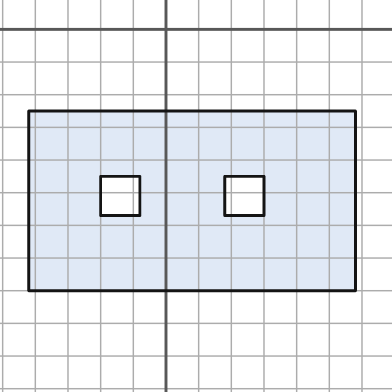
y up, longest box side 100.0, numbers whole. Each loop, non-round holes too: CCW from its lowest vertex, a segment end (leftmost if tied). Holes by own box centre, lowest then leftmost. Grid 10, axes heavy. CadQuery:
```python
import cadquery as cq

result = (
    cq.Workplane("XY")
    .moveTo(-42.0, -80.0)
    .lineTo(58.0, -80.0)
    .lineTo(58.0, -25.0)
    .lineTo(-42.0, -25.0)
    .close()
    .moveTo(-20.0, -57.0)
    .lineTo(-8.0, -57.0)
    .lineTo(-8.0, -45.0)
    .lineTo(-20.0, -45.0)
    .close()
    .moveTo(18.0, -57.0)
    .lineTo(30.0, -57.0)
    .lineTo(30.0, -45.0)
    .lineTo(18.0, -45.0)
    .close()
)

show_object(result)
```